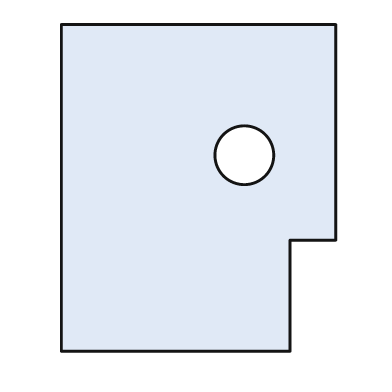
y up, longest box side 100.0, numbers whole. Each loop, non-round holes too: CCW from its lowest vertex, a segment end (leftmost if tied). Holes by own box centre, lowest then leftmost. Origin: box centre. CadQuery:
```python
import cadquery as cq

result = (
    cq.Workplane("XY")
    .moveTo(-42.0, -50.0)
    .lineTo(28.0, -50.0)
    .lineTo(28.0, -16.0)
    .lineTo(42.0, -16.0)
    .lineTo(42.0, 50.0)
    .lineTo(-42.0, 50.0)
    .close()
    .moveTo(14.0, 10.0)
    .circle(9.0)
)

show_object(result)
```